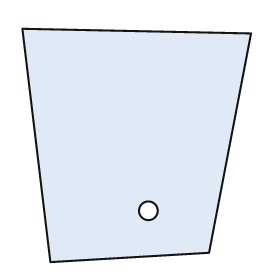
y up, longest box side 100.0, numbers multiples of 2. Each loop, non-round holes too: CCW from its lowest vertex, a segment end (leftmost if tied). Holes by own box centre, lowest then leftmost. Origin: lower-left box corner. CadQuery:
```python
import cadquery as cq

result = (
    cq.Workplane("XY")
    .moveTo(12.0, 0.0)
    .lineTo(80.0, 4.0)
    .lineTo(98.0, 98.0)
    .lineTo(0.0, 100.0)
    .close()
    .moveTo(54.0, 22.0)
    .circle(4.0)
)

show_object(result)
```